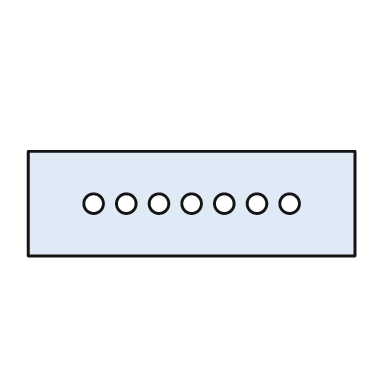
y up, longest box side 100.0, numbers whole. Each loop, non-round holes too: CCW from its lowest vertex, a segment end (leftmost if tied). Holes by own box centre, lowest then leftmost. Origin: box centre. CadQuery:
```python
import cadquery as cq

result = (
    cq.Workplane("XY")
    .moveTo(-50.0, -16.0)
    .lineTo(50.0, -16.0)
    .lineTo(50.0, 16.0)
    .lineTo(-50.0, 16.0)
    .close()
    .moveTo(-30.0, 0.0)
    .circle(3.0)
    .moveTo(-20.0, 0.0)
    .circle(3.0)
    .moveTo(-10.0, 0.0)
    .circle(3.0)
    .moveTo(0.0, 0.0)
    .circle(3.0)
    .moveTo(10.0, 0.0)
    .circle(3.0)
    .moveTo(20.0, 0.0)
    .circle(3.0)
    .moveTo(30.0, 0.0)
    .circle(3.0)
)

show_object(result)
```